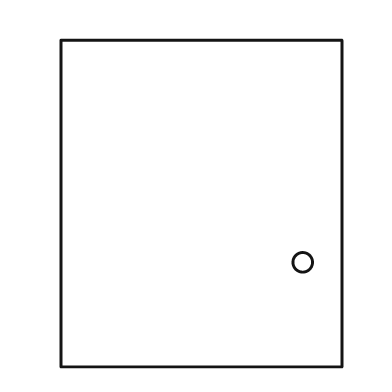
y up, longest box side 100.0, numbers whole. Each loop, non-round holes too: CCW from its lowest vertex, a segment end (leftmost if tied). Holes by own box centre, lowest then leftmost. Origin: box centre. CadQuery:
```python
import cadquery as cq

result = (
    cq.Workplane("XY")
    .moveTo(-43.0, -50.0)
    .lineTo(43.0, -50.0)
    .lineTo(43.0, 50.0)
    .lineTo(-43.0, 50.0)
    .close()
    .moveTo(31.0, -18.0)
    .circle(3.0)
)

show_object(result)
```